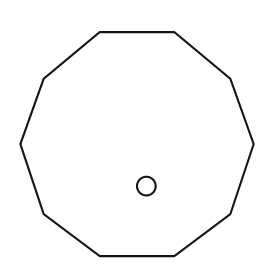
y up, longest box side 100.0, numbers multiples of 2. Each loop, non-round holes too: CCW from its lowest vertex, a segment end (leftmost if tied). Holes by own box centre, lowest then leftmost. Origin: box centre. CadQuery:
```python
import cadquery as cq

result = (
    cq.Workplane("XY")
    .moveTo(-16.0, -48.0)
    .lineTo(16.0, -48.0)
    .lineTo(40.0, -30.0)
    .lineTo(50.0, 0.0)
    .lineTo(40.0, 28.0)
    .lineTo(16.0, 48.0)
    .lineTo(-16.0, 48.0)
    .lineTo(-40.0, 28.0)
    .lineTo(-50.0, 0.0)
    .lineTo(-40.0, -30.0)
    .close()
    .moveTo(4.0, -18.0)
    .circle(4.0)
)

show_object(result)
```